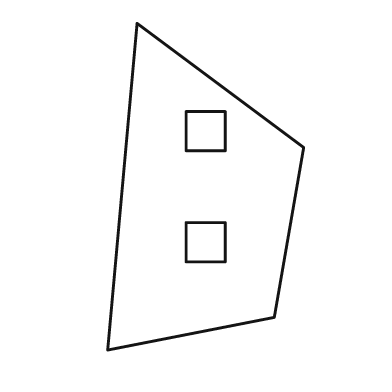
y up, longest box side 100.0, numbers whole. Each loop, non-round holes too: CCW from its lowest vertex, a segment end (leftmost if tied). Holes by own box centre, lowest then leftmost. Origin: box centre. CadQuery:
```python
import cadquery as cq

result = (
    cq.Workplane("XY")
    .moveTo(-30.0, -50.0)
    .lineTo(21.0, -40.0)
    .lineTo(30.0, 12.0)
    .lineTo(-21.0, 50.0)
    .close()
    .moveTo(-6.0, -23.0)
    .lineTo(6.0, -23.0)
    .lineTo(6.0, -11.0)
    .lineTo(-6.0, -11.0)
    .close()
    .moveTo(-6.0, 11.0)
    .lineTo(6.0, 11.0)
    .lineTo(6.0, 23.0)
    .lineTo(-6.0, 23.0)
    .close()
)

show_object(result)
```